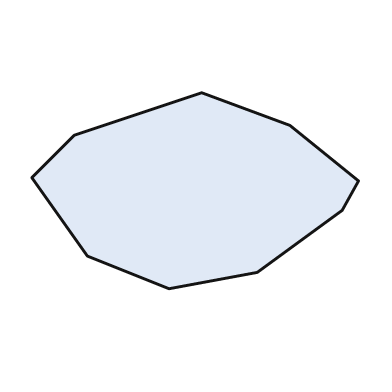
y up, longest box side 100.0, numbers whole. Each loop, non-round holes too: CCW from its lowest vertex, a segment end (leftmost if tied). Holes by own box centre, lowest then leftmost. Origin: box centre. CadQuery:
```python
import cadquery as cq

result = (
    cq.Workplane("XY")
    .moveTo(-8.0, -30.0)
    .lineTo(19.0, -25.0)
    .lineTo(45.0, -6.0)
    .lineTo(50.0, 3.0)
    .lineTo(29.0, 20.0)
    .lineTo(2.0, 30.0)
    .lineTo(-37.0, 17.0)
    .lineTo(-50.0, 4.0)
    .lineTo(-33.0, -20.0)
    .close()
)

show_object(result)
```